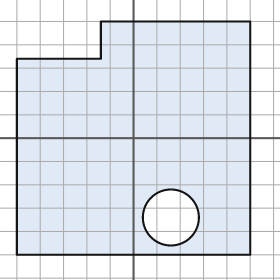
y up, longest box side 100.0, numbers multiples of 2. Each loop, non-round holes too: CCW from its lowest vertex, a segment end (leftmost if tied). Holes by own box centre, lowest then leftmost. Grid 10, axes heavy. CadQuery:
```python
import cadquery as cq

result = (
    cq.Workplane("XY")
    .moveTo(-50.0, -50.0)
    .lineTo(50.0, -50.0)
    .lineTo(50.0, 50.0)
    .lineTo(-14.0, 50.0)
    .lineTo(-14.0, 34.0)
    .lineTo(-50.0, 34.0)
    .close()
    .moveTo(16.0, -34.0)
    .circle(12.0)
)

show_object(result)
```